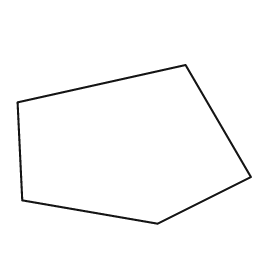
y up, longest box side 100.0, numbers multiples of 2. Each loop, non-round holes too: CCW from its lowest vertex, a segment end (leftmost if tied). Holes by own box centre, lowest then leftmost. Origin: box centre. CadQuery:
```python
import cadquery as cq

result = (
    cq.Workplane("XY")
    .moveTo(10.0, -34.0)
    .lineTo(50.0, -14.0)
    .lineTo(22.0, 34.0)
    .lineTo(-50.0, 18.0)
    .lineTo(-48.0, -24.0)
    .close()
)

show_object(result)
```